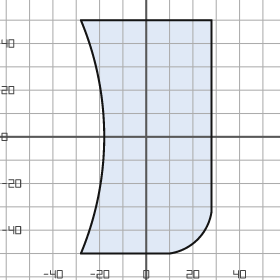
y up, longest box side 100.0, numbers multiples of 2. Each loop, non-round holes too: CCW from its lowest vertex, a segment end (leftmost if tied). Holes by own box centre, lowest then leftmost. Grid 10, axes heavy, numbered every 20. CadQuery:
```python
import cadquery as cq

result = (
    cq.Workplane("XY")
    .moveTo(-28.0, -50.0)
    .lineTo(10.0, -50.0)
    .threePointArc((22.0, -44.0), (28.0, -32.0))
    .lineTo(28.0, 50.0)
    .lineTo(-28.0, 50.0)
    .threePointArc((-18.0, 0.0), (-28.0, -50.0))
    .close()
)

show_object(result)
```